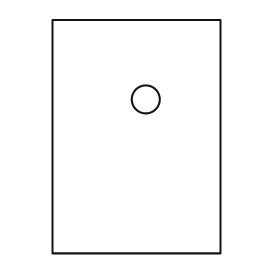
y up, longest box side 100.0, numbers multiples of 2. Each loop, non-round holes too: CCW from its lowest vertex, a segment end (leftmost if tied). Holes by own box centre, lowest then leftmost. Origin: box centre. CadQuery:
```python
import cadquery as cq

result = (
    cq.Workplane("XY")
    .moveTo(-36.0, -50.0)
    .lineTo(36.0, -50.0)
    .lineTo(36.0, 50.0)
    .lineTo(-36.0, 50.0)
    .close()
    .moveTo(4.0, 16.0)
    .circle(6.0)
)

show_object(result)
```